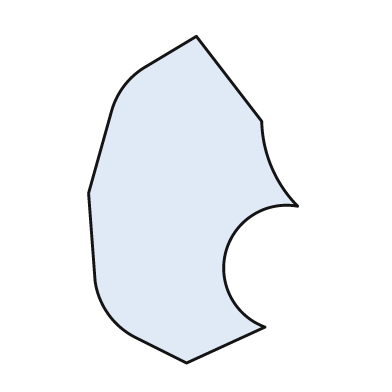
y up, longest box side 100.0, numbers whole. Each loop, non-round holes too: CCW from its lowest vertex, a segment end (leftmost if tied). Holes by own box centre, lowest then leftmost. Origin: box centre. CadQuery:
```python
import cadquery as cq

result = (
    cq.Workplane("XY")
    .moveTo(-2.0, -50.0)
    .lineTo(22.0, -39.0)
    .threePointArc((10.0, -16.0), (32.0, -2.0))
    .threePointArc((24.0, 10.0), (21.0, 24.0))
    .lineTo(1.0, 50.0)
    .lineTo(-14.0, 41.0)
    .threePointArc((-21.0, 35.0), (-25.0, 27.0))
    .lineTo(-32.0, 2.0)
    .lineTo(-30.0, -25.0)
    .threePointArc((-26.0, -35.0), (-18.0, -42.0))
    .close()
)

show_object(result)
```